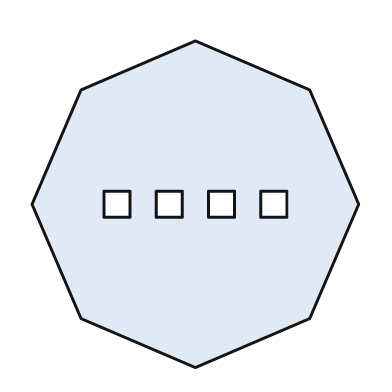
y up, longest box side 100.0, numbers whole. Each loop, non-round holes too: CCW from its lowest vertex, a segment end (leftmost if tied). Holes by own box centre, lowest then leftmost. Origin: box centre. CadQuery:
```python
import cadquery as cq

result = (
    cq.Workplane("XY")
    .moveTo(0.0, -50.0)
    .lineTo(35.0, -35.0)
    .lineTo(50.0, 0.0)
    .lineTo(35.0, 35.0)
    .lineTo(0.0, 50.0)
    .lineTo(-35.0, 35.0)
    .lineTo(-50.0, 0.0)
    .lineTo(-35.0, -35.0)
    .close()
    .moveTo(-28.0, -4.0)
    .lineTo(-20.0, -4.0)
    .lineTo(-20.0, 4.0)
    .lineTo(-28.0, 4.0)
    .close()
    .moveTo(-12.0, -4.0)
    .lineTo(-4.0, -4.0)
    .lineTo(-4.0, 4.0)
    .lineTo(-12.0, 4.0)
    .close()
    .moveTo(4.0, -4.0)
    .lineTo(12.0, -4.0)
    .lineTo(12.0, 4.0)
    .lineTo(4.0, 4.0)
    .close()
    .moveTo(20.0, -4.0)
    .lineTo(28.0, -4.0)
    .lineTo(28.0, 4.0)
    .lineTo(20.0, 4.0)
    .close()
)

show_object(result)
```